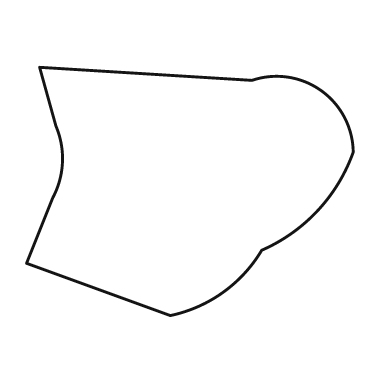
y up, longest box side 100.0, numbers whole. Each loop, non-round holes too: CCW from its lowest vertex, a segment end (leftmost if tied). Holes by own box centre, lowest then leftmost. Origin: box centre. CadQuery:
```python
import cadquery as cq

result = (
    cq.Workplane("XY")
    .moveTo(-6.0, -38.0)
    .threePointArc((10.0, -31.0), (22.0, -18.0))
    .threePointArc((39.0, -6.0), (50.0, 12.0))
    .threePointArc((40.0, 31.0), (19.0, 34.0))
    .lineTo(-46.0, 38.0)
    .lineTo(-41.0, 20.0)
    .threePointArc((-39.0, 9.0), (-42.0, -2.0))
    .lineTo(-50.0, -22.0)
    .close()
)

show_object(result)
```